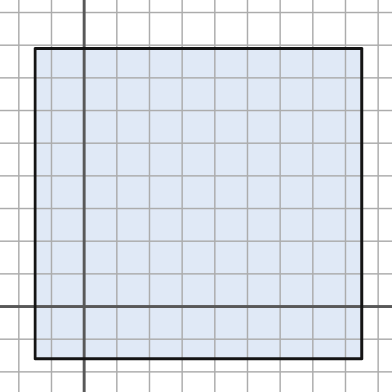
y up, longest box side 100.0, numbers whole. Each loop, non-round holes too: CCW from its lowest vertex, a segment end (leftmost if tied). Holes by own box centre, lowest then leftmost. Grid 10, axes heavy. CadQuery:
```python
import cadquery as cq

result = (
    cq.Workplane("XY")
    .moveTo(-15.0, -16.0)
    .lineTo(85.0, -16.0)
    .lineTo(85.0, 79.0)
    .lineTo(-15.0, 79.0)
    .close()
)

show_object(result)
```